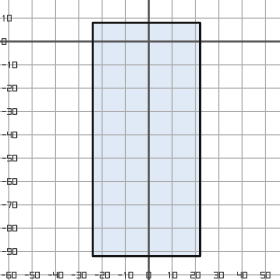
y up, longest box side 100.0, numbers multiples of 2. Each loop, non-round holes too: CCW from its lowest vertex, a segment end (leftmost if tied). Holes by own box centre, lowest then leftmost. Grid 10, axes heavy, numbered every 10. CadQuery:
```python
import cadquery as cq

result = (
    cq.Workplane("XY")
    .moveTo(-24.0, -92.0)
    .lineTo(22.0, -92.0)
    .lineTo(22.0, 8.0)
    .lineTo(-24.0, 8.0)
    .close()
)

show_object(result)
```